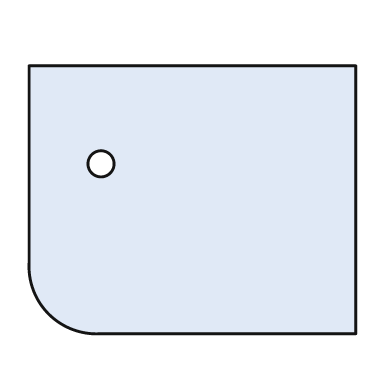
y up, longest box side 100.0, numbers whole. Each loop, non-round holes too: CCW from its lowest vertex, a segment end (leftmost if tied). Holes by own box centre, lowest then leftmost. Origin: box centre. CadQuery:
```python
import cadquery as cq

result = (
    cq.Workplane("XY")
    .moveTo(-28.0, -41.0)
    .lineTo(50.0, -41.0)
    .lineTo(50.0, 41.0)
    .lineTo(-50.0, 41.0)
    .lineTo(-50.0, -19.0)
    .threePointArc((-44.0, -35.0), (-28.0, -41.0))
    .close()
    .moveTo(-28.0, 11.0)
    .circle(4.0)
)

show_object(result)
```